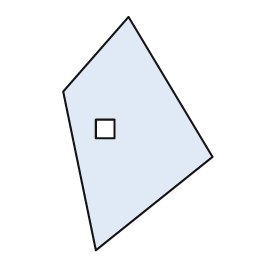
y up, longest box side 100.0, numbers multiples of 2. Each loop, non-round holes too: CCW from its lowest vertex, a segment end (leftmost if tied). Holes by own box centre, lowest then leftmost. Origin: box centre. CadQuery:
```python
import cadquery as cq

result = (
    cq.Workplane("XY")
    .moveTo(-18.0, -50.0)
    .lineTo(32.0, -10.0)
    .lineTo(-4.0, 50.0)
    .lineTo(-32.0, 18.0)
    .close()
    .moveTo(-18.0, -2.0)
    .lineTo(-10.0, -2.0)
    .lineTo(-10.0, 6.0)
    .lineTo(-18.0, 6.0)
    .close()
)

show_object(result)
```